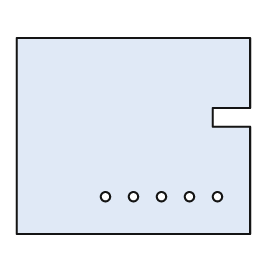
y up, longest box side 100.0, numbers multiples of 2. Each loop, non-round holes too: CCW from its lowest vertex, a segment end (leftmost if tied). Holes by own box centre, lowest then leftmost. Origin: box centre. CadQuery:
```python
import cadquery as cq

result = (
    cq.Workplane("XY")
    .moveTo(-50.0, -42.0)
    .lineTo(50.0, -42.0)
    .lineTo(50.0, 4.0)
    .lineTo(34.0, 4.0)
    .lineTo(34.0, 12.0)
    .lineTo(50.0, 12.0)
    .lineTo(50.0, 42.0)
    .lineTo(-50.0, 42.0)
    .close()
    .moveTo(-12.0, -26.0)
    .circle(2.0)
    .moveTo(0.0, -26.0)
    .circle(2.0)
    .moveTo(12.0, -26.0)
    .circle(2.0)
    .moveTo(24.0, -26.0)
    .circle(2.0)
    .moveTo(36.0, -26.0)
    .circle(2.0)
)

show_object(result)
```